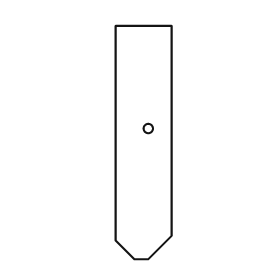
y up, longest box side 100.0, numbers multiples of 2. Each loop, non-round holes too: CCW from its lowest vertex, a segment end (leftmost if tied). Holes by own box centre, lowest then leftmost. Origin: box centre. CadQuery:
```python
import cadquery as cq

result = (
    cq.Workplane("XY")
    .moveTo(-4.0, -50.0)
    .lineTo(2.0, -50.0)
    .lineTo(12.0, -40.0)
    .lineTo(12.0, 50.0)
    .lineTo(-12.0, 50.0)
    .lineTo(-12.0, -42.0)
    .close()
    .moveTo(2.0, 6.0)
    .circle(2.0)
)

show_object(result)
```